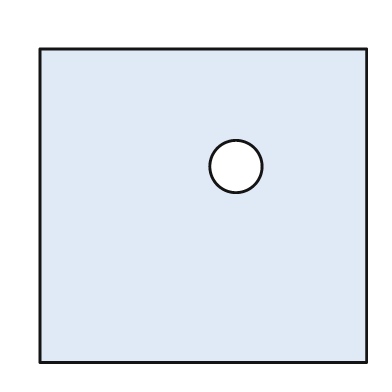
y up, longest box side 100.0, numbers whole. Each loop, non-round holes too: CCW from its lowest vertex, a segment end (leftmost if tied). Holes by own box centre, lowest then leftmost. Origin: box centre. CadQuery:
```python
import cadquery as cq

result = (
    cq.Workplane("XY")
    .moveTo(-50.0, -48.0)
    .lineTo(50.0, -48.0)
    .lineTo(50.0, 48.0)
    .lineTo(-50.0, 48.0)
    .close()
    .moveTo(10.0, 12.0)
    .circle(8.0)
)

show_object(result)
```